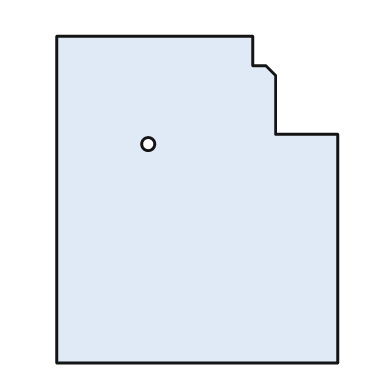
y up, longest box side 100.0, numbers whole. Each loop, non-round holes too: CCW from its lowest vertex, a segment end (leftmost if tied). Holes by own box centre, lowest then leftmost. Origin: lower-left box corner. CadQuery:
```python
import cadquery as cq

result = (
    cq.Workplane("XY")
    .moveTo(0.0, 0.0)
    .lineTo(86.0, 0.0)
    .lineTo(86.0, 70.0)
    .lineTo(67.0, 70.0)
    .lineTo(67.0, 88.0)
    .lineTo(64.0, 91.0)
    .lineTo(60.0, 91.0)
    .lineTo(60.0, 100.0)
    .lineTo(0.0, 100.0)
    .close()
    .moveTo(28.0, 67.0)
    .circle(2.0)
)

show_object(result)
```